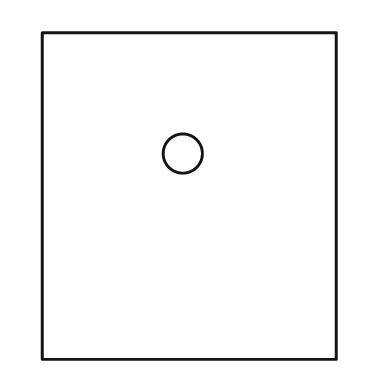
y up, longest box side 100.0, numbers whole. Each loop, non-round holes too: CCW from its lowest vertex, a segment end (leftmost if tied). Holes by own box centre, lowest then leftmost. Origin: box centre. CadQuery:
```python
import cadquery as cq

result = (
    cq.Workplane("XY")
    .moveTo(-45.0, -50.0)
    .lineTo(45.0, -50.0)
    .lineTo(45.0, 50.0)
    .lineTo(-45.0, 50.0)
    .close()
    .moveTo(-2.0, 13.0)
    .circle(6.0)
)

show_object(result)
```